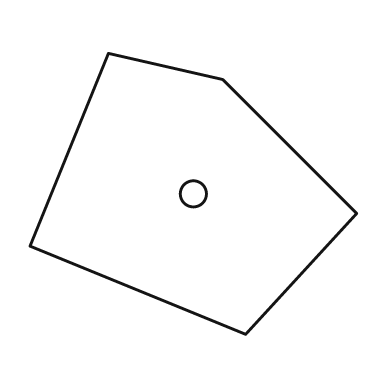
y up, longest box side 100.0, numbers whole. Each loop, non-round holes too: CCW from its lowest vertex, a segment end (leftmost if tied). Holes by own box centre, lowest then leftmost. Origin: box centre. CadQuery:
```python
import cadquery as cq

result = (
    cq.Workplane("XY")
    .moveTo(16.0, -43.0)
    .lineTo(50.0, -6.0)
    .lineTo(9.0, 35.0)
    .lineTo(-26.0, 43.0)
    .lineTo(-50.0, -16.0)
    .close()
    .moveTo(0.0, 0.0)
    .circle(4.0)
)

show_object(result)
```